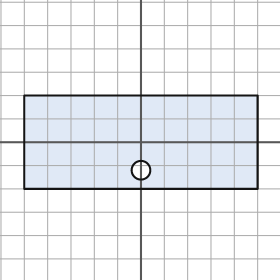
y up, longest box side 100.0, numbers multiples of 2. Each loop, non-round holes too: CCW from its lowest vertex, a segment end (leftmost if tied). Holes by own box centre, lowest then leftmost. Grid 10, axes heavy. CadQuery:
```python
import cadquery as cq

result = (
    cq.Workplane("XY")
    .moveTo(-50.0, -20.0)
    .lineTo(50.0, -20.0)
    .lineTo(50.0, 20.0)
    .lineTo(-50.0, 20.0)
    .close()
    .moveTo(0.0, -12.0)
    .circle(4.0)
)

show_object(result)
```